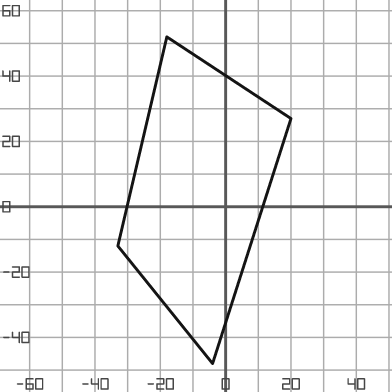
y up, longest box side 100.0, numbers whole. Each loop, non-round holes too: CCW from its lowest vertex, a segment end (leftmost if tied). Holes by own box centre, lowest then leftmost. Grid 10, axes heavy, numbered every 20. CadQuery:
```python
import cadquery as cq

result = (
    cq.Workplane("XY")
    .moveTo(-4.0, -48.0)
    .lineTo(20.0, 27.0)
    .lineTo(-18.0, 52.0)
    .lineTo(-33.0, -12.0)
    .close()
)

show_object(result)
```